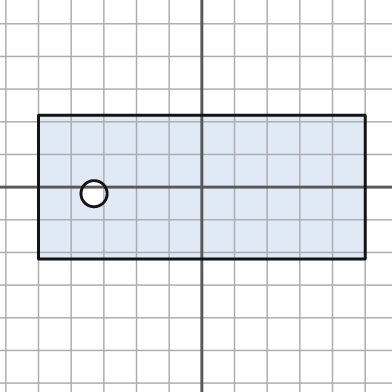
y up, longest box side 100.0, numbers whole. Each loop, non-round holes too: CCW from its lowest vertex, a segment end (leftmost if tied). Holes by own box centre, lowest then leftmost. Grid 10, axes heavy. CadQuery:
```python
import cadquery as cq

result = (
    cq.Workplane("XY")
    .moveTo(-50.0, -22.0)
    .lineTo(50.0, -22.0)
    .lineTo(50.0, 22.0)
    .lineTo(-50.0, 22.0)
    .close()
    .moveTo(-33.0, -2.0)
    .circle(4.0)
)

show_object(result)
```